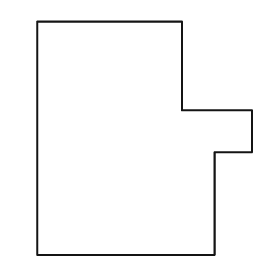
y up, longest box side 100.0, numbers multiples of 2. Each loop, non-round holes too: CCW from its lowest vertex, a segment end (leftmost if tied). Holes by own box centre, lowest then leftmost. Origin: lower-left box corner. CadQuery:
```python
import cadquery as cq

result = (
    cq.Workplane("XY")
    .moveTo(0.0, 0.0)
    .lineTo(76.0, 0.0)
    .lineTo(76.0, 44.0)
    .lineTo(92.0, 44.0)
    .lineTo(92.0, 62.0)
    .lineTo(62.0, 62.0)
    .lineTo(62.0, 100.0)
    .lineTo(0.0, 100.0)
    .close()
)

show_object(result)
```